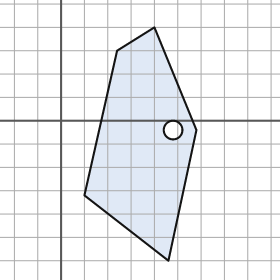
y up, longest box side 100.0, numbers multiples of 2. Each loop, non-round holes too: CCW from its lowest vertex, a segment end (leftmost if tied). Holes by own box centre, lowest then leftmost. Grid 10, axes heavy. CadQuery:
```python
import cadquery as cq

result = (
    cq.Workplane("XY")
    .moveTo(46.0, -60.0)
    .lineTo(58.0, -4.0)
    .lineTo(40.0, 40.0)
    .lineTo(24.0, 30.0)
    .lineTo(10.0, -32.0)
    .close()
    .moveTo(48.0, -4.0)
    .circle(4.0)
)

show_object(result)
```